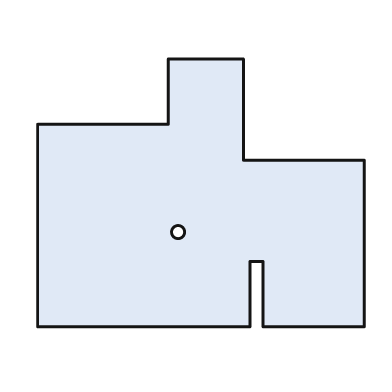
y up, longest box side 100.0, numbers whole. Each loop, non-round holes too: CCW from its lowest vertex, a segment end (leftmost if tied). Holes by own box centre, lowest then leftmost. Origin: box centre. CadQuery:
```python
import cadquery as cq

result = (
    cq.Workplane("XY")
    .moveTo(-50.0, -41.0)
    .lineTo(15.0, -41.0)
    .lineTo(15.0, -21.0)
    .lineTo(19.0, -21.0)
    .lineTo(19.0, -41.0)
    .lineTo(50.0, -41.0)
    .lineTo(50.0, 10.0)
    .lineTo(13.0, 10.0)
    .lineTo(13.0, 41.0)
    .lineTo(-10.0, 41.0)
    .lineTo(-10.0, 21.0)
    .lineTo(-50.0, 21.0)
    .close()
    .moveTo(-7.0, -12.0)
    .circle(2.0)
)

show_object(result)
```